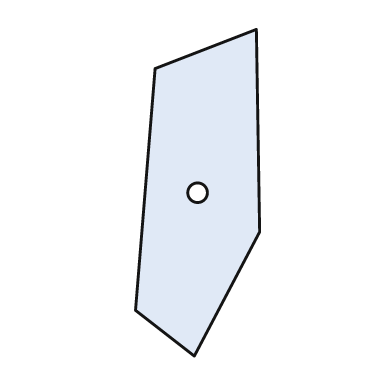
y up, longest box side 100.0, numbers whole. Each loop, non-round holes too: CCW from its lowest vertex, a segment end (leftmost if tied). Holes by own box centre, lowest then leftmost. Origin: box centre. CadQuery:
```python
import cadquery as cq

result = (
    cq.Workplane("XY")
    .moveTo(-1.0, -50.0)
    .lineTo(19.0, -12.0)
    .lineTo(18.0, 50.0)
    .lineTo(-13.0, 38.0)
    .lineTo(-19.0, -36.0)
    .close()
    .moveTo(0.0, 0.0)
    .circle(3.0)
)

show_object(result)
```